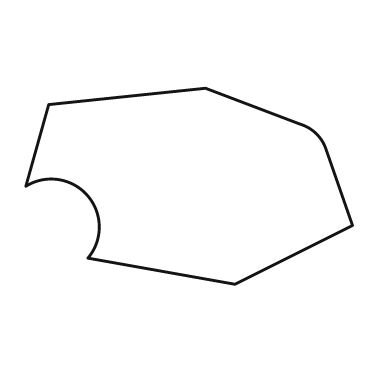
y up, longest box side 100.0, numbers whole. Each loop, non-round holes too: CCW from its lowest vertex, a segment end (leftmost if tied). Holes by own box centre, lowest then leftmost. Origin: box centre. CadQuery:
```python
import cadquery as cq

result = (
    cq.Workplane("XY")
    .moveTo(14.0, -30.0)
    .lineTo(50.0, -12.0)
    .lineTo(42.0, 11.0)
    .threePointArc((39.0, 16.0), (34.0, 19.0))
    .lineTo(5.0, 30.0)
    .lineTo(-43.0, 25.0)
    .lineTo(-50.0, 0.0)
    .threePointArc((-31.0, -3.0), (-31.0, -22.0))
    .close()
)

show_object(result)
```